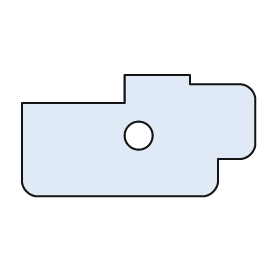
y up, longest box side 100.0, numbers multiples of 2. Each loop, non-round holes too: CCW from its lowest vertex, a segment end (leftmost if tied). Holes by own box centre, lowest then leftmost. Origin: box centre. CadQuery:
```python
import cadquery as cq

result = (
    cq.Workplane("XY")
    .moveTo(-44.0, -26.0)
    .lineTo(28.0, -26.0)
    .threePointArc((32.0, -24.0), (34.0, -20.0))
    .lineTo(34.0, -10.0)
    .lineTo(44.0, -10.0)
    .threePointArc((48.0, -8.0), (50.0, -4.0))
    .lineTo(50.0, 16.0)
    .threePointArc((48.0, 20.0), (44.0, 22.0))
    .lineTo(22.0, 22.0)
    .lineTo(22.0, 26.0)
    .lineTo(-6.0, 26.0)
    .lineTo(-6.0, 14.0)
    .lineTo(-50.0, 14.0)
    .lineTo(-50.0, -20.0)
    .threePointArc((-48.0, -24.0), (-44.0, -26.0))
    .close()
    .moveTo(0.0, 0.0)
    .circle(6.0)
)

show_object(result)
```